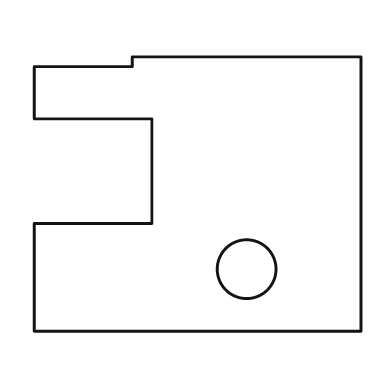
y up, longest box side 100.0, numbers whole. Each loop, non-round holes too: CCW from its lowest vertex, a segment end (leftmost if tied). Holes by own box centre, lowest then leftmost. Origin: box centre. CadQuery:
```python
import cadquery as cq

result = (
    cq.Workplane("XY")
    .moveTo(-50.0, -42.0)
    .lineTo(50.0, -42.0)
    .lineTo(50.0, 42.0)
    .lineTo(-20.0, 42.0)
    .lineTo(-20.0, 39.0)
    .lineTo(-50.0, 39.0)
    .lineTo(-50.0, 23.0)
    .lineTo(-14.0, 23.0)
    .lineTo(-14.0, -9.0)
    .lineTo(-50.0, -9.0)
    .close()
    .moveTo(15.0, -23.0)
    .circle(9.0)
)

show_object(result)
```